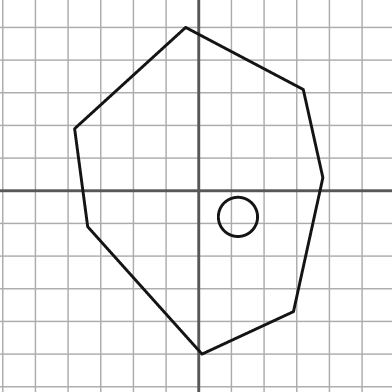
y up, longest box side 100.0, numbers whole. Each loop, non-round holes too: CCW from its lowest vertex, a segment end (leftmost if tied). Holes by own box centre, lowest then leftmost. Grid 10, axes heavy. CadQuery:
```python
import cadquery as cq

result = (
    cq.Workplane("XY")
    .moveTo(1.0, -50.0)
    .lineTo(29.0, -37.0)
    .lineTo(38.0, 4.0)
    .lineTo(32.0, 31.0)
    .lineTo(-4.0, 50.0)
    .lineTo(-38.0, 19.0)
    .lineTo(-34.0, -11.0)
    .close()
    .moveTo(12.0, -8.0)
    .circle(6.0)
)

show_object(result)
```